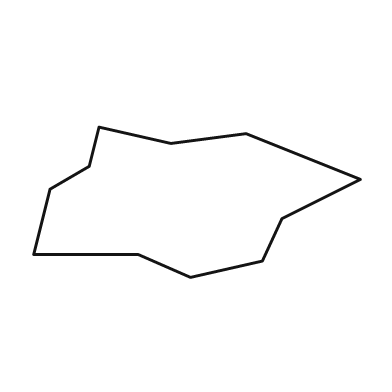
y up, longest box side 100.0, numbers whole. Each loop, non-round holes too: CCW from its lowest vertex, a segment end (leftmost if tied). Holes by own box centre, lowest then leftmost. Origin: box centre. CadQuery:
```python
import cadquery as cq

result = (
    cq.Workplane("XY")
    .moveTo(-2.0, -23.0)
    .lineTo(20.0, -18.0)
    .lineTo(26.0, -5.0)
    .lineTo(50.0, 7.0)
    .lineTo(15.0, 21.0)
    .lineTo(-8.0, 18.0)
    .lineTo(-30.0, 23.0)
    .lineTo(-33.0, 11.0)
    .lineTo(-45.0, 4.0)
    .lineTo(-50.0, -16.0)
    .lineTo(-18.0, -16.0)
    .close()
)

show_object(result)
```